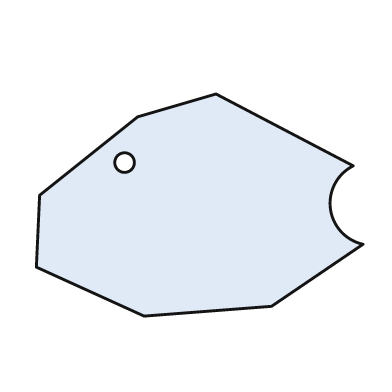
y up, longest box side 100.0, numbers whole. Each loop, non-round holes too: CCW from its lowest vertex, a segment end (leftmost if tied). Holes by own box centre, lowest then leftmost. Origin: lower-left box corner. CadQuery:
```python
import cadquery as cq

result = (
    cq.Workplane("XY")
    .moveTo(33.0, 0.0)
    .lineTo(72.0, 3.0)
    .lineTo(100.0, 22.0)
    .threePointArc((90.0, 33.0), (97.0, 46.0))
    .lineTo(55.0, 68.0)
    .lineTo(31.0, 61.0)
    .lineTo(1.0, 37.0)
    .lineTo(0.0, 15.0)
    .close()
    .moveTo(27.0, 47.0)
    .circle(3.0)
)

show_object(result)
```